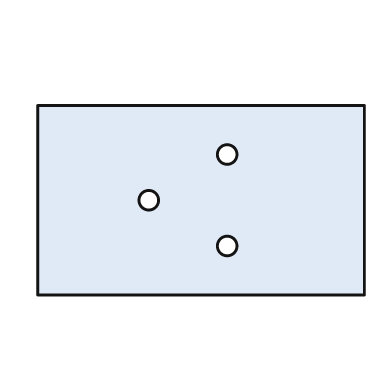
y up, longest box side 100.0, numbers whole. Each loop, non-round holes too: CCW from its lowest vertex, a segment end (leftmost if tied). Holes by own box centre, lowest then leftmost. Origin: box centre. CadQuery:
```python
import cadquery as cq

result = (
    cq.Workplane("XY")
    .moveTo(-50.0, -29.0)
    .lineTo(50.0, -29.0)
    .lineTo(50.0, 29.0)
    .lineTo(-50.0, 29.0)
    .close()
    .moveTo(8.0, -14.0)
    .circle(3.0)
    .moveTo(-16.0, 0.0)
    .circle(3.0)
    .moveTo(8.0, 14.0)
    .circle(3.0)
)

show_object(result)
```